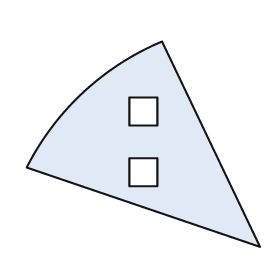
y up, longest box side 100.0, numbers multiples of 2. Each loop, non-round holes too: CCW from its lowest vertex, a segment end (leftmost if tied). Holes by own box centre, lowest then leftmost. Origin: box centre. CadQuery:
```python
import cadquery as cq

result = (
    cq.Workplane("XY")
    .moveTo(50.0, -44.0)
    .lineTo(8.0, 44.0)
    .threePointArc((-26.0, 22.0), (-50.0, -10.0))
    .close()
    .moveTo(-6.0, -18.0)
    .lineTo(6.0, -18.0)
    .lineTo(6.0, -6.0)
    .lineTo(-6.0, -6.0)
    .close()
    .moveTo(-6.0, 8.0)
    .lineTo(6.0, 8.0)
    .lineTo(6.0, 20.0)
    .lineTo(-6.0, 20.0)
    .close()
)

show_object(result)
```